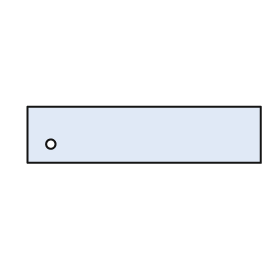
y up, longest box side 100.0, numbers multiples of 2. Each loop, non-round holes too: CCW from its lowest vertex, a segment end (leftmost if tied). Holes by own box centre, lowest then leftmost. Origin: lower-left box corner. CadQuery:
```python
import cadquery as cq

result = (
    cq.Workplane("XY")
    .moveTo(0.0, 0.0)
    .lineTo(100.0, 0.0)
    .lineTo(100.0, 24.0)
    .lineTo(0.0, 24.0)
    .close()
    .moveTo(10.0, 8.0)
    .circle(2.0)
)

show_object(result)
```